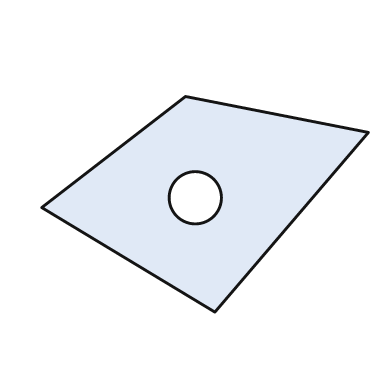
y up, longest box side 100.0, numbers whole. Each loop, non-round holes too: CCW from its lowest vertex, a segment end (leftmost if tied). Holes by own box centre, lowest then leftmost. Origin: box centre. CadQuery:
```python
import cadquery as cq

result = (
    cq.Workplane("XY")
    .moveTo(3.0, -33.0)
    .lineTo(50.0, 22.0)
    .lineTo(-6.0, 33.0)
    .lineTo(-50.0, -1.0)
    .close()
    .moveTo(-3.0, 2.0)
    .circle(8.0)
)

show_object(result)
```